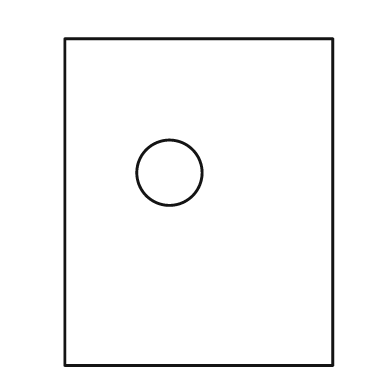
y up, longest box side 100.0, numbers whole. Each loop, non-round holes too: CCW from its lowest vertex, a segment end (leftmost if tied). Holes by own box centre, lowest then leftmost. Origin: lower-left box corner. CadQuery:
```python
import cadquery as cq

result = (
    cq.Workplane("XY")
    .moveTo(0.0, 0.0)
    .lineTo(82.0, 0.0)
    .lineTo(82.0, 100.0)
    .lineTo(0.0, 100.0)
    .close()
    .moveTo(32.0, 59.0)
    .circle(10.0)
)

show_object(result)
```